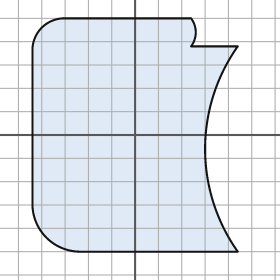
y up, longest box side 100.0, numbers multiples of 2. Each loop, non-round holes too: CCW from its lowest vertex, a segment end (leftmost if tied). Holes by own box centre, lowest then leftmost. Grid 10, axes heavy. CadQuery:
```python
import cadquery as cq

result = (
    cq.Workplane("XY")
    .moveTo(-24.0, -50.0)
    .lineTo(44.0, -50.0)
    .threePointArc((30.0, -6.0), (44.0, 38.0))
    .lineTo(24.0, 38.0)
    .threePointArc((26.0, 44.0), (24.0, 50.0))
    .lineTo(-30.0, 50.0)
    .threePointArc((-40.0, 46.0), (-44.0, 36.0))
    .lineTo(-44.0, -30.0)
    .threePointArc((-38.0, -44.0), (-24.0, -50.0))
    .close()
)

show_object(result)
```